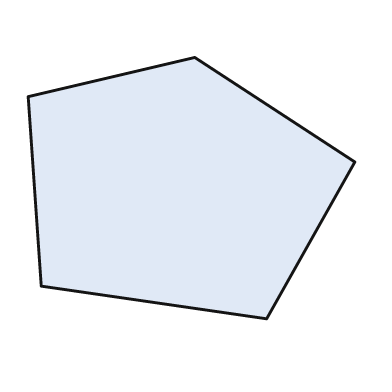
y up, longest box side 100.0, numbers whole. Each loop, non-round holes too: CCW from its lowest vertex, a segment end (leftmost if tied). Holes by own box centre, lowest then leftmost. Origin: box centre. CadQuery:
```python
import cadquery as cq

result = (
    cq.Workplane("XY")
    .moveTo(23.0, -40.0)
    .lineTo(50.0, 8.0)
    .lineTo(1.0, 40.0)
    .lineTo(-50.0, 28.0)
    .lineTo(-46.0, -30.0)
    .close()
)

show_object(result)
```